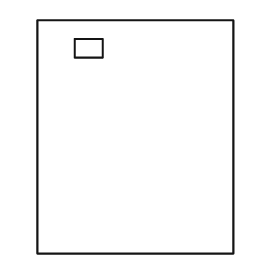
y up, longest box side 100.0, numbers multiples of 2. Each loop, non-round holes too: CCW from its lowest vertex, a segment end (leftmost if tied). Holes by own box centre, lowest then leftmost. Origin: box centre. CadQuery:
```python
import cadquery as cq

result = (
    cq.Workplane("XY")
    .moveTo(-42.0, -50.0)
    .lineTo(42.0, -50.0)
    .lineTo(42.0, 50.0)
    .lineTo(-42.0, 50.0)
    .close()
    .moveTo(-26.0, 34.0)
    .lineTo(-14.0, 34.0)
    .lineTo(-14.0, 42.0)
    .lineTo(-26.0, 42.0)
    .close()
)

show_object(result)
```